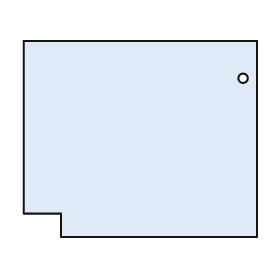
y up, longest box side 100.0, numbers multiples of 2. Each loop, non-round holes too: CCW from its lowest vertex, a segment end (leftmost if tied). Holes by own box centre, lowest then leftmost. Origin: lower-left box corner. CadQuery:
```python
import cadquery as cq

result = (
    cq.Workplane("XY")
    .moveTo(16.0, 0.0)
    .lineTo(100.0, 0.0)
    .lineTo(100.0, 84.0)
    .lineTo(0.0, 84.0)
    .lineTo(0.0, 10.0)
    .lineTo(16.0, 10.0)
    .close()
    .moveTo(94.0, 68.0)
    .circle(2.0)
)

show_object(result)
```